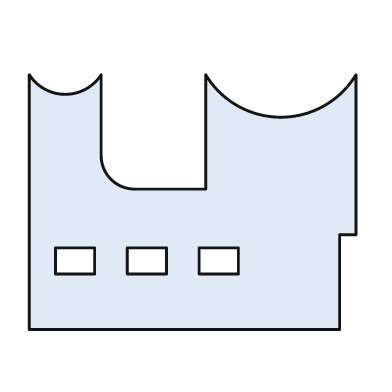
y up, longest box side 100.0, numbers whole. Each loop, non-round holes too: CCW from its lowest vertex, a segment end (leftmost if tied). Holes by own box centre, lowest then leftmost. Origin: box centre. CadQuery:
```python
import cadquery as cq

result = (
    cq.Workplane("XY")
    .moveTo(-50.0, -39.0)
    .lineTo(45.0, -39.0)
    .lineTo(45.0, -10.0)
    .lineTo(50.0, -10.0)
    .lineTo(50.0, 39.0)
    .threePointArc((27.0, 26.0), (4.0, 39.0))
    .lineTo(4.0, 4.0)
    .lineTo(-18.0, 4.0)
    .threePointArc((-25.0, 7.0), (-28.0, 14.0))
    .lineTo(-28.0, 39.0)
    .threePointArc((-39.0, 33.0), (-50.0, 39.0))
    .close()
    .moveTo(-42.0, -22.0)
    .lineTo(-30.0, -22.0)
    .lineTo(-30.0, -14.0)
    .lineTo(-42.0, -14.0)
    .close()
    .moveTo(-20.0, -22.0)
    .lineTo(-8.0, -22.0)
    .lineTo(-8.0, -14.0)
    .lineTo(-20.0, -14.0)
    .close()
    .moveTo(2.0, -22.0)
    .lineTo(14.0, -22.0)
    .lineTo(14.0, -14.0)
    .lineTo(2.0, -14.0)
    .close()
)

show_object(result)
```